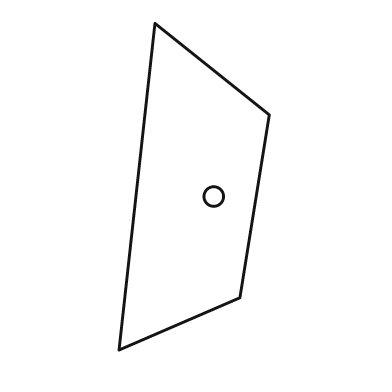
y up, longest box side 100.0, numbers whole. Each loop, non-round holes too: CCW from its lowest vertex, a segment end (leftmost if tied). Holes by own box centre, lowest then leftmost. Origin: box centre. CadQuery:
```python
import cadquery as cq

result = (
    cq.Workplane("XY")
    .moveTo(-23.0, -50.0)
    .lineTo(14.0, -34.0)
    .lineTo(23.0, 22.0)
    .lineTo(-12.0, 50.0)
    .close()
    .moveTo(6.0, -3.0)
    .circle(3.0)
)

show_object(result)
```